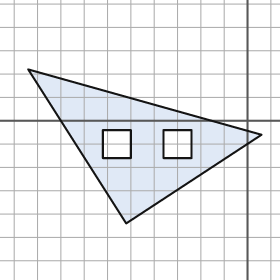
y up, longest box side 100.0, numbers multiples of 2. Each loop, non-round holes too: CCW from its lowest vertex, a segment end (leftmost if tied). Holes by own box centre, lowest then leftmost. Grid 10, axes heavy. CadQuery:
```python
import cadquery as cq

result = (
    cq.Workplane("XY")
    .moveTo(-52.0, -44.0)
    .lineTo(6.0, -6.0)
    .lineTo(-94.0, 22.0)
    .close()
    .moveTo(-62.0, -16.0)
    .lineTo(-50.0, -16.0)
    .lineTo(-50.0, -4.0)
    .lineTo(-62.0, -4.0)
    .close()
    .moveTo(-36.0, -16.0)
    .lineTo(-24.0, -16.0)
    .lineTo(-24.0, -4.0)
    .lineTo(-36.0, -4.0)
    .close()
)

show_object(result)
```